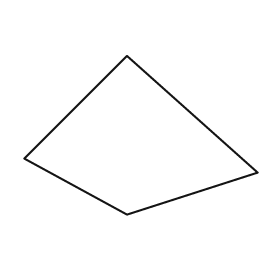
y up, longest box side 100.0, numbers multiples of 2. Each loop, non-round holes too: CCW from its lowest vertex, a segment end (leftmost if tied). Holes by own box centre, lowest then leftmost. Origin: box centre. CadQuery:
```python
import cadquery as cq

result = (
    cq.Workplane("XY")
    .moveTo(-6.0, -34.0)
    .lineTo(50.0, -16.0)
    .lineTo(-6.0, 34.0)
    .lineTo(-50.0, -10.0)
    .close()
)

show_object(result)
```